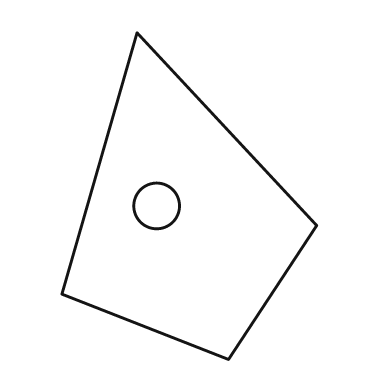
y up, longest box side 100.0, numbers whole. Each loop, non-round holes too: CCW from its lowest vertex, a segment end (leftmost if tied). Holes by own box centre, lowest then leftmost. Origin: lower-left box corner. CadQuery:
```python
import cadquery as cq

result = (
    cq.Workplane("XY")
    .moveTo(51.0, 0.0)
    .lineTo(78.0, 41.0)
    .lineTo(23.0, 100.0)
    .lineTo(0.0, 20.0)
    .close()
    .moveTo(29.0, 47.0)
    .circle(7.0)
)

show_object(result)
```